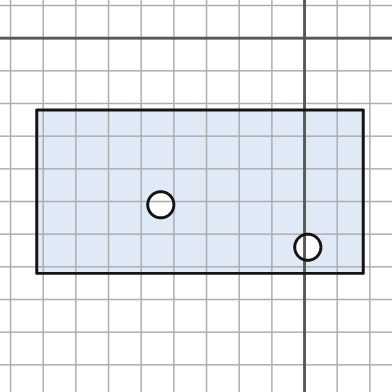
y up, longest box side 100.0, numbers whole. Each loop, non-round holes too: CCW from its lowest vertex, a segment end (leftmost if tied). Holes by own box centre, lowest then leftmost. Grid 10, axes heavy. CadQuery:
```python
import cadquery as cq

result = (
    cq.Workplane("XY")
    .moveTo(-82.0, -72.0)
    .lineTo(18.0, -72.0)
    .lineTo(18.0, -22.0)
    .lineTo(-82.0, -22.0)
    .close()
    .moveTo(1.0, -64.0)
    .circle(4.0)
    .moveTo(-44.0, -51.0)
    .circle(4.0)
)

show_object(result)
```